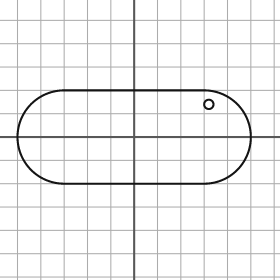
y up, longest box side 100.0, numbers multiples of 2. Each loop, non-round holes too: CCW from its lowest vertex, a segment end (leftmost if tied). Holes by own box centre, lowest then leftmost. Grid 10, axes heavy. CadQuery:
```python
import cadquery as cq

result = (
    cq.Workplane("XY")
    .moveTo(-30.0, -20.0)
    .lineTo(30.0, -20.0)
    .threePointArc((50.0, 0.0), (30.0, 20.0))
    .lineTo(-30.0, 20.0)
    .threePointArc((-50.0, 0.0), (-30.0, -20.0))
    .close()
    .moveTo(32.0, 14.0)
    .circle(2.0)
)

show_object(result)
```